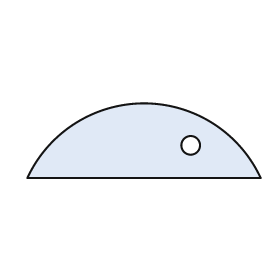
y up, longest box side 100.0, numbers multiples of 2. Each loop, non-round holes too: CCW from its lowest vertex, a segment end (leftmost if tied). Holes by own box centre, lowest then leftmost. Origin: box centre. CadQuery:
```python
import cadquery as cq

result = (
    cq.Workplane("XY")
    .moveTo(-50.0, -16.0)
    .lineTo(50.0, -16.0)
    .threePointArc((0.0, 16.0), (-50.0, -16.0))
    .close()
    .moveTo(20.0, -2.0)
    .circle(4.0)
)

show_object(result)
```